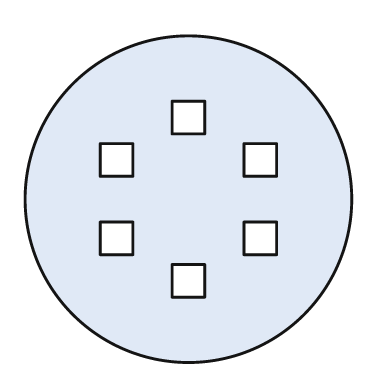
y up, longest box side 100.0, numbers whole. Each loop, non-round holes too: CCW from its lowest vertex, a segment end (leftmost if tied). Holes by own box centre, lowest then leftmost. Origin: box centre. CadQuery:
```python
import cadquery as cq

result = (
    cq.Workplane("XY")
    .moveTo(0.0, 0.0)
    .circle(50.0)
    .moveTo(-5.0, -30.0)
    .lineTo(5.0, -30.0)
    .lineTo(5.0, -20.0)
    .lineTo(-5.0, -20.0)
    .close()
    .moveTo(-27.0, -17.0)
    .lineTo(-17.0, -17.0)
    .lineTo(-17.0, -7.0)
    .lineTo(-27.0, -7.0)
    .close()
    .moveTo(17.0, -17.0)
    .lineTo(27.0, -17.0)
    .lineTo(27.0, -7.0)
    .lineTo(17.0, -7.0)
    .close()
    .moveTo(-27.0, 7.0)
    .lineTo(-17.0, 7.0)
    .lineTo(-17.0, 17.0)
    .lineTo(-27.0, 17.0)
    .close()
    .moveTo(17.0, 7.0)
    .lineTo(27.0, 7.0)
    .lineTo(27.0, 17.0)
    .lineTo(17.0, 17.0)
    .close()
    .moveTo(-5.0, 20.0)
    .lineTo(5.0, 20.0)
    .lineTo(5.0, 30.0)
    .lineTo(-5.0, 30.0)
    .close()
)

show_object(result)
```